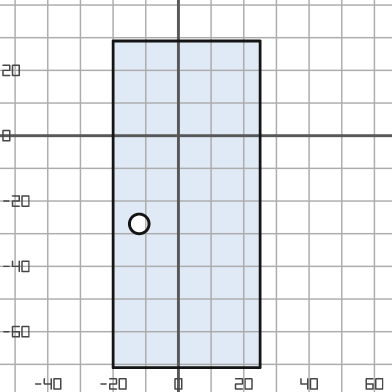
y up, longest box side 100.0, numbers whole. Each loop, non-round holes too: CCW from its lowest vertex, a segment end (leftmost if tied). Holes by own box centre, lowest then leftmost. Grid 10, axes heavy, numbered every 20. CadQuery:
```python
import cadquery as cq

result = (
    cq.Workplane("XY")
    .moveTo(-20.0, -71.0)
    .lineTo(25.0, -71.0)
    .lineTo(25.0, 29.0)
    .lineTo(-20.0, 29.0)
    .close()
    .moveTo(-12.0, -27.0)
    .circle(3.0)
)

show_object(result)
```